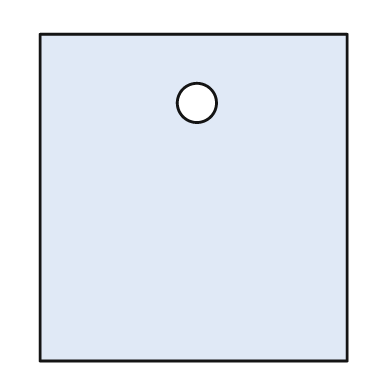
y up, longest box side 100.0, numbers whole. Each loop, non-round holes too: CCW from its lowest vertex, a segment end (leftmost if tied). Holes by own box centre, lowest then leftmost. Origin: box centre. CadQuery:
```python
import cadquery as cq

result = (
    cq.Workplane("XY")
    .moveTo(-47.0, -50.0)
    .lineTo(47.0, -50.0)
    .lineTo(47.0, 50.0)
    .lineTo(-47.0, 50.0)
    .close()
    .moveTo(1.0, 29.0)
    .circle(6.0)
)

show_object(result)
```